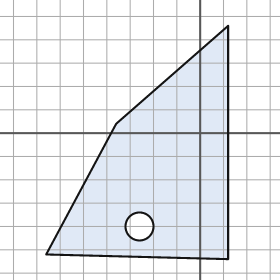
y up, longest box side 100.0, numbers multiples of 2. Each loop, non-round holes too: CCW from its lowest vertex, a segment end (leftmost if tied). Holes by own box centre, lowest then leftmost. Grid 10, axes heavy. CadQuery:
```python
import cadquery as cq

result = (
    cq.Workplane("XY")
    .moveTo(12.0, -54.0)
    .lineTo(12.0, 46.0)
    .lineTo(-36.0, 4.0)
    .lineTo(-66.0, -52.0)
    .close()
    .moveTo(-26.0, -40.0)
    .circle(6.0)
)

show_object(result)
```